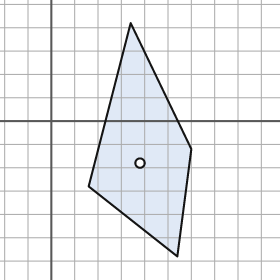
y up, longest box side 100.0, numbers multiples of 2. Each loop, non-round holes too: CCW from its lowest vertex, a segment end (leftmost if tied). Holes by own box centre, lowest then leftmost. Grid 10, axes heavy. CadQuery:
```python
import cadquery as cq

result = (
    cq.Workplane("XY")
    .moveTo(54.0, -58.0)
    .lineTo(60.0, -12.0)
    .lineTo(34.0, 42.0)
    .lineTo(16.0, -28.0)
    .close()
    .moveTo(38.0, -18.0)
    .circle(2.0)
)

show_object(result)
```